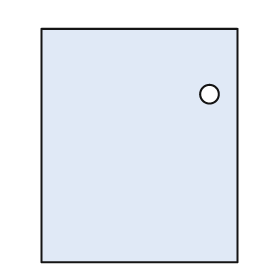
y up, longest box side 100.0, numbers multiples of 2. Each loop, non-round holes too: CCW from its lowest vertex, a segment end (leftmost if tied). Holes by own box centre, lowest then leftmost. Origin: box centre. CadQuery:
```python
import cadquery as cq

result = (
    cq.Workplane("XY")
    .moveTo(-42.0, -50.0)
    .lineTo(42.0, -50.0)
    .lineTo(42.0, 50.0)
    .lineTo(-42.0, 50.0)
    .close()
    .moveTo(30.0, 22.0)
    .circle(4.0)
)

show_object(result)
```